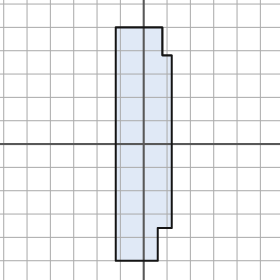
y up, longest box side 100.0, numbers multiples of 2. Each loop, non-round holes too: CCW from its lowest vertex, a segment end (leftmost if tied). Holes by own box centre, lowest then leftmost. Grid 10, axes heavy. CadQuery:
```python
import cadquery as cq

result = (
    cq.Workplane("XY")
    .moveTo(-12.0, -50.0)
    .lineTo(6.0, -50.0)
    .lineTo(6.0, -36.0)
    .lineTo(12.0, -36.0)
    .lineTo(12.0, 38.0)
    .lineTo(8.0, 38.0)
    .lineTo(8.0, 50.0)
    .lineTo(-12.0, 50.0)
    .close()
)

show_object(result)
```